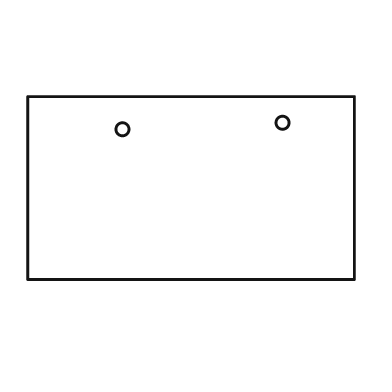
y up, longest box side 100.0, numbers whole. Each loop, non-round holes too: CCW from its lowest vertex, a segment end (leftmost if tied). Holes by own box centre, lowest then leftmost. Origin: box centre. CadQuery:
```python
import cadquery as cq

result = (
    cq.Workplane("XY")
    .moveTo(-50.0, -28.0)
    .lineTo(50.0, -28.0)
    .lineTo(50.0, 28.0)
    .lineTo(-50.0, 28.0)
    .close()
    .moveTo(-21.0, 18.0)
    .circle(2.0)
    .moveTo(28.0, 20.0)
    .circle(2.0)
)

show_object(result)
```